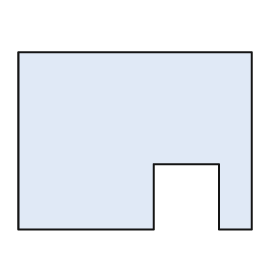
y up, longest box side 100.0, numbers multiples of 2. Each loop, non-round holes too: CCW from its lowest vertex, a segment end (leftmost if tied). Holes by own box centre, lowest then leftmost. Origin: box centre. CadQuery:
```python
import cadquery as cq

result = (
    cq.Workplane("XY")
    .moveTo(-50.0, -38.0)
    .lineTo(8.0, -38.0)
    .lineTo(8.0, -10.0)
    .lineTo(36.0, -10.0)
    .lineTo(36.0, -38.0)
    .lineTo(50.0, -38.0)
    .lineTo(50.0, 38.0)
    .lineTo(-50.0, 38.0)
    .close()
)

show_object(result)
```